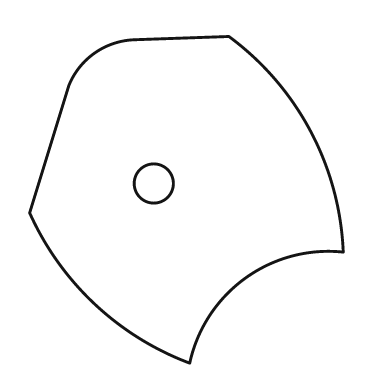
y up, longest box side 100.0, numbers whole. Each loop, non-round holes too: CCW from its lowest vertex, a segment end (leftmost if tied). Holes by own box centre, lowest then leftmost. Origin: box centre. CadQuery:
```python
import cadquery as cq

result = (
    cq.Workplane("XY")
    .moveTo(1.0, -50.0)
    .threePointArc((18.0, -24.0), (48.0, -16.0))
    .threePointArc((38.0, 21.0), (13.0, 50.0))
    .lineTo(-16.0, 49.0)
    .threePointArc((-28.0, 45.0), (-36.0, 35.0))
    .lineTo(-48.0, -4.0)
    .threePointArc((-28.0, -32.0), (1.0, -50.0))
    .close()
    .moveTo(-10.0, 5.0)
    .circle(6.0)
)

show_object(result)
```